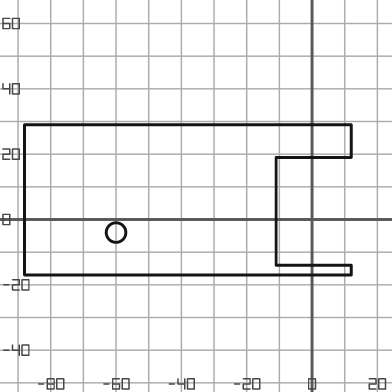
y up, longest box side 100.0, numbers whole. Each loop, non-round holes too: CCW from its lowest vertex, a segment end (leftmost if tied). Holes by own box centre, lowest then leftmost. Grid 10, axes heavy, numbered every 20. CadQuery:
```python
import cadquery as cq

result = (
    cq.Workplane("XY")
    .moveTo(-88.0, -17.0)
    .lineTo(12.0, -17.0)
    .lineTo(12.0, -14.0)
    .lineTo(-11.0, -14.0)
    .lineTo(-11.0, 19.0)
    .lineTo(12.0, 19.0)
    .lineTo(12.0, 29.0)
    .lineTo(-88.0, 29.0)
    .close()
    .moveTo(-60.0, -4.0)
    .circle(3.0)
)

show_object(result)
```